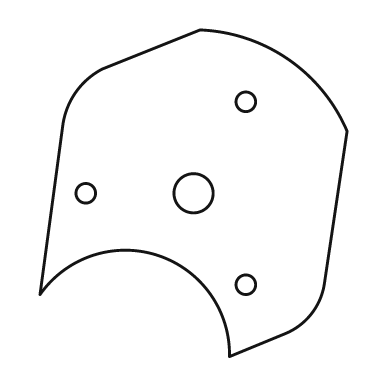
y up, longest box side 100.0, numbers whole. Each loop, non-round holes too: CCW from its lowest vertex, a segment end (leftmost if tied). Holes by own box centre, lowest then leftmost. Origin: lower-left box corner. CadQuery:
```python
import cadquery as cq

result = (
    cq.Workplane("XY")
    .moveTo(58.0, 0.0)
    .lineTo(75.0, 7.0)
    .threePointArc((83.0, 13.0), (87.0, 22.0))
    .lineTo(94.0, 69.0)
    .threePointArc((76.0, 91.0), (49.0, 100.0))
    .lineTo(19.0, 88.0)
    .threePointArc((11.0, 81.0), (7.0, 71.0))
    .lineTo(0.0, 19.0)
    .threePointArc((36.0, 31.0), (58.0, 0.0))
    .close()
    .moveTo(63.0, 22.0)
    .circle(3.0)
    .moveTo(14.0, 50.0)
    .circle(3.0)
    .moveTo(47.0, 50.0)
    .circle(6.0)
    .moveTo(63.0, 78.0)
    .circle(3.0)
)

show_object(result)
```